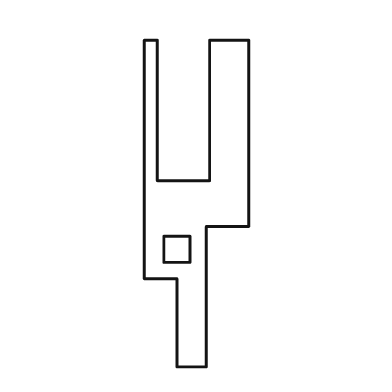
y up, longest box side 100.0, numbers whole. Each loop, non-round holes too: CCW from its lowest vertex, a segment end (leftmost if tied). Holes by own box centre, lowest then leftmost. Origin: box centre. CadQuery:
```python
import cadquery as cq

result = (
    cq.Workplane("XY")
    .moveTo(-6.0, -50.0)
    .lineTo(3.0, -50.0)
    .lineTo(3.0, -7.0)
    .lineTo(16.0, -7.0)
    .lineTo(16.0, 50.0)
    .lineTo(4.0, 50.0)
    .lineTo(4.0, 7.0)
    .lineTo(-12.0, 7.0)
    .lineTo(-12.0, 50.0)
    .lineTo(-16.0, 50.0)
    .lineTo(-16.0, -23.0)
    .lineTo(-6.0, -23.0)
    .close()
    .moveTo(-10.0, -18.0)
    .lineTo(-2.0, -18.0)
    .lineTo(-2.0, -10.0)
    .lineTo(-10.0, -10.0)
    .close()
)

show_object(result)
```